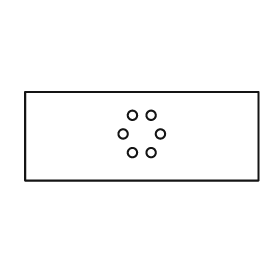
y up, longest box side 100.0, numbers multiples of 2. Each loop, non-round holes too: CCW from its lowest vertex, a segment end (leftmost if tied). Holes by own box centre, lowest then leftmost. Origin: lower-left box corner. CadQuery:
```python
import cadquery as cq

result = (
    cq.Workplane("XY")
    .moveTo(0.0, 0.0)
    .lineTo(100.0, 0.0)
    .lineTo(100.0, 38.0)
    .lineTo(0.0, 38.0)
    .close()
    .moveTo(46.0, 12.0)
    .circle(2.0)
    .moveTo(54.0, 12.0)
    .circle(2.0)
    .moveTo(42.0, 20.0)
    .circle(2.0)
    .moveTo(58.0, 20.0)
    .circle(2.0)
    .moveTo(46.0, 28.0)
    .circle(2.0)
    .moveTo(54.0, 28.0)
    .circle(2.0)
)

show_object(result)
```